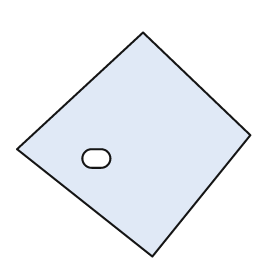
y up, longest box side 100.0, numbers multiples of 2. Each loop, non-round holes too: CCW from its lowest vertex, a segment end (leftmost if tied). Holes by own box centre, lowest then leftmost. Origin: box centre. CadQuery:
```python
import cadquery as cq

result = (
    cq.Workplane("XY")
    .moveTo(8.0, -48.0)
    .lineTo(50.0, 4.0)
    .lineTo(4.0, 48.0)
    .lineTo(-50.0, -2.0)
    .close()
    .moveTo(-18.0, -10.0)
    .lineTo(-14.0, -10.0)
    .threePointArc((-10.0, -6.0), (-14.0, -2.0))
    .lineTo(-18.0, -2.0)
    .threePointArc((-22.0, -6.0), (-18.0, -10.0))
    .close()
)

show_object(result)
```